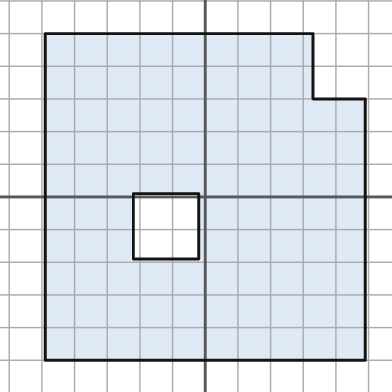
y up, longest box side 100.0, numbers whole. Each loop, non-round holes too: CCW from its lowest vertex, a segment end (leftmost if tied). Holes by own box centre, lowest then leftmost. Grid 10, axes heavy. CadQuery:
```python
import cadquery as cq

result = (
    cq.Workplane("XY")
    .moveTo(-49.0, -50.0)
    .lineTo(49.0, -50.0)
    .lineTo(49.0, 30.0)
    .lineTo(33.0, 30.0)
    .lineTo(33.0, 50.0)
    .lineTo(-49.0, 50.0)
    .close()
    .moveTo(-22.0, -19.0)
    .lineTo(-2.0, -19.0)
    .lineTo(-2.0, 1.0)
    .lineTo(-22.0, 1.0)
    .close()
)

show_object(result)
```